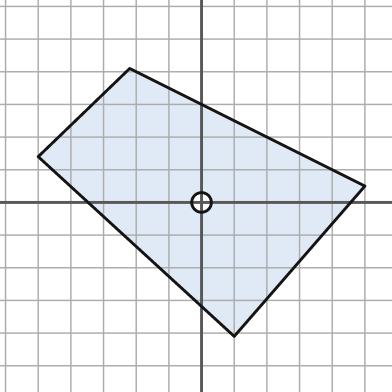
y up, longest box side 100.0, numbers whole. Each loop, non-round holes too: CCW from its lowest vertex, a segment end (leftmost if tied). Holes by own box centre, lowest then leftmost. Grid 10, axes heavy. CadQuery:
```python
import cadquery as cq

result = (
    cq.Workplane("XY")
    .moveTo(10.0, -41.0)
    .lineTo(50.0, 5.0)
    .lineTo(-22.0, 41.0)
    .lineTo(-50.0, 14.0)
    .close()
    .moveTo(0.0, 0.0)
    .circle(3.0)
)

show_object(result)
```